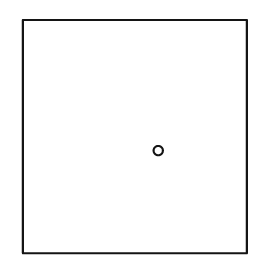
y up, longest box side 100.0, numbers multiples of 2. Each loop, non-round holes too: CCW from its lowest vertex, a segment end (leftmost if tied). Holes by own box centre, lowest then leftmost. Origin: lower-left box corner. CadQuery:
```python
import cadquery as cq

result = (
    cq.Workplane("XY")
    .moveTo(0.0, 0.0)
    .lineTo(96.0, 0.0)
    .lineTo(96.0, 100.0)
    .lineTo(0.0, 100.0)
    .close()
    .moveTo(58.0, 44.0)
    .circle(2.0)
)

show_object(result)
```